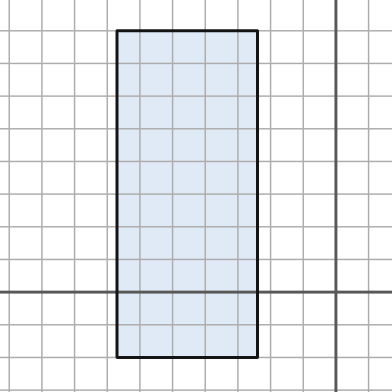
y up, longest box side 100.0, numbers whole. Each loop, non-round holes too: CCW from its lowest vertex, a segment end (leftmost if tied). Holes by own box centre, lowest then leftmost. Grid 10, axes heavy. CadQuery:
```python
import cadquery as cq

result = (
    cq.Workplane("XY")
    .moveTo(-67.0, -20.0)
    .lineTo(-24.0, -20.0)
    .lineTo(-24.0, 80.0)
    .lineTo(-67.0, 80.0)
    .close()
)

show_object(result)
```